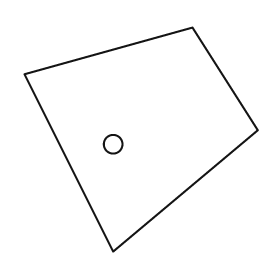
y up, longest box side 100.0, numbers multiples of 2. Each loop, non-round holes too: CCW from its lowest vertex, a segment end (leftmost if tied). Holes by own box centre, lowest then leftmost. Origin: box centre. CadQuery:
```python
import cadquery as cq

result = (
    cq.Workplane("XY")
    .moveTo(-12.0, -48.0)
    .lineTo(50.0, 4.0)
    .lineTo(22.0, 48.0)
    .lineTo(-50.0, 28.0)
    .close()
    .moveTo(-12.0, -2.0)
    .circle(4.0)
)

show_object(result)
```